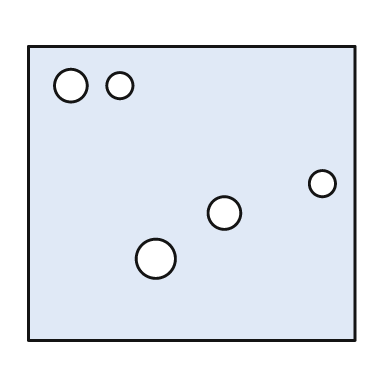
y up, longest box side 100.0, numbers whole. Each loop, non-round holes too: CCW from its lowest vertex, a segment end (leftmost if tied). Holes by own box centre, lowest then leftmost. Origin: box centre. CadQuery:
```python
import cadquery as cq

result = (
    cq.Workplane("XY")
    .moveTo(-50.0, -45.0)
    .lineTo(50.0, -45.0)
    .lineTo(50.0, 45.0)
    .lineTo(-50.0, 45.0)
    .close()
    .moveTo(-11.0, -20.0)
    .circle(6.0)
    .moveTo(10.0, -6.0)
    .circle(5.0)
    .moveTo(40.0, 3.0)
    .circle(4.0)
    .moveTo(-37.0, 33.0)
    .circle(5.0)
    .moveTo(-22.0, 33.0)
    .circle(4.0)
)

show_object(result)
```